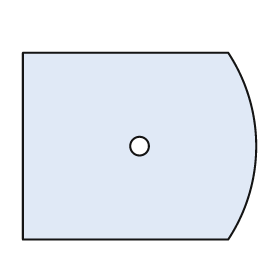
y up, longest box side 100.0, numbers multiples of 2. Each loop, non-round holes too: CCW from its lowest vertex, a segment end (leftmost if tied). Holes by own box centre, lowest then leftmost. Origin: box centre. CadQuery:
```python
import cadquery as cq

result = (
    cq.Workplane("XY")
    .moveTo(-50.0, -40.0)
    .lineTo(38.0, -40.0)
    .threePointArc((50.0, 0.0), (38.0, 40.0))
    .lineTo(-50.0, 40.0)
    .close()
    .moveTo(0.0, 0.0)
    .circle(4.0)
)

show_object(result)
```